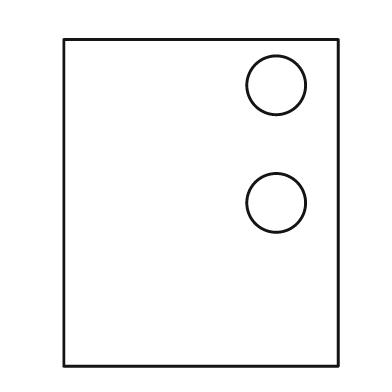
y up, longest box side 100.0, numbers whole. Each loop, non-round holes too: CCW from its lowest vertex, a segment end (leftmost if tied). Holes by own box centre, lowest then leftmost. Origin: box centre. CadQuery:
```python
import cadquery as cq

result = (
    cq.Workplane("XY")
    .moveTo(-42.0, -50.0)
    .lineTo(42.0, -50.0)
    .lineTo(42.0, 50.0)
    .lineTo(-42.0, 50.0)
    .close()
    .moveTo(23.0, 0.0)
    .circle(9.0)
    .moveTo(23.0, 36.0)
    .circle(9.0)
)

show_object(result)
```